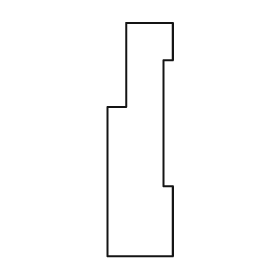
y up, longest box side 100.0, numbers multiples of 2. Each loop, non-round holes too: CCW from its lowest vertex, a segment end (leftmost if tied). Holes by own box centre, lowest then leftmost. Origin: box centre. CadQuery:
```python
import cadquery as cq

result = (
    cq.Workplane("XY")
    .moveTo(-14.0, -50.0)
    .lineTo(14.0, -50.0)
    .lineTo(14.0, -20.0)
    .lineTo(10.0, -20.0)
    .lineTo(10.0, 34.0)
    .lineTo(14.0, 34.0)
    .lineTo(14.0, 50.0)
    .lineTo(-6.0, 50.0)
    .lineTo(-6.0, 14.0)
    .lineTo(-14.0, 14.0)
    .close()
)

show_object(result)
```